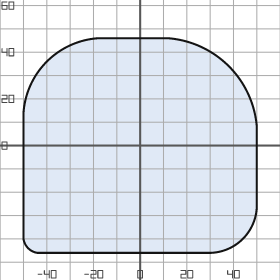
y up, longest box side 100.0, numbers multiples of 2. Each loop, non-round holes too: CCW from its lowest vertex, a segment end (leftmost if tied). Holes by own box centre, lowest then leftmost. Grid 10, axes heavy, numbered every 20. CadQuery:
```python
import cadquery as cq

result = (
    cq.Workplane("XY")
    .moveTo(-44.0, -46.0)
    .lineTo(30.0, -46.0)
    .threePointArc((44.0, -40.0), (50.0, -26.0))
    .lineTo(50.0, 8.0)
    .threePointArc((38.0, 34.0), (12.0, 46.0))
    .lineTo(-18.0, 46.0)
    .threePointArc((-40.0, 36.0), (-50.0, 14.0))
    .lineTo(-50.0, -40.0)
    .threePointArc((-48.0, -44.0), (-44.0, -46.0))
    .close()
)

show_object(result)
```